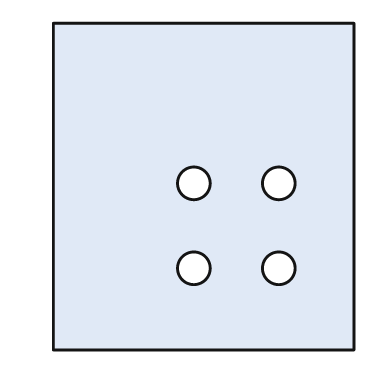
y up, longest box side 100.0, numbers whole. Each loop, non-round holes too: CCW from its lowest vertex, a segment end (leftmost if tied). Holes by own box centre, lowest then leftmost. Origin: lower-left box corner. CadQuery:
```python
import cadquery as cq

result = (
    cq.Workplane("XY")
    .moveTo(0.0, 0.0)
    .lineTo(92.0, 0.0)
    .lineTo(92.0, 100.0)
    .lineTo(0.0, 100.0)
    .close()
    .moveTo(43.0, 25.0)
    .circle(5.0)
    .moveTo(69.0, 25.0)
    .circle(5.0)
    .moveTo(43.0, 51.0)
    .circle(5.0)
    .moveTo(69.0, 51.0)
    .circle(5.0)
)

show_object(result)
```